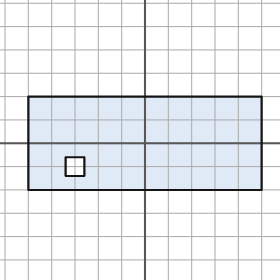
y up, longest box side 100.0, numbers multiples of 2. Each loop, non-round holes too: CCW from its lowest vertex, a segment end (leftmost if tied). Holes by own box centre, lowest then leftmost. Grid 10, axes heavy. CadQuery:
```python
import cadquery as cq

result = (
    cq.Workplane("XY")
    .moveTo(-50.0, -20.0)
    .lineTo(50.0, -20.0)
    .lineTo(50.0, 20.0)
    .lineTo(-50.0, 20.0)
    .close()
    .moveTo(-34.0, -14.0)
    .lineTo(-26.0, -14.0)
    .lineTo(-26.0, -6.0)
    .lineTo(-34.0, -6.0)
    .close()
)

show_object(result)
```